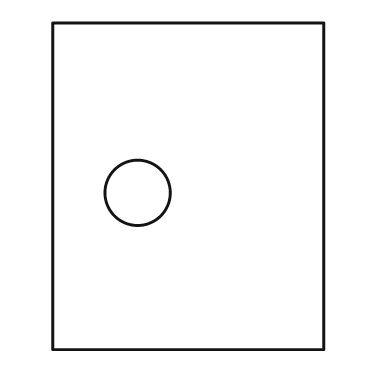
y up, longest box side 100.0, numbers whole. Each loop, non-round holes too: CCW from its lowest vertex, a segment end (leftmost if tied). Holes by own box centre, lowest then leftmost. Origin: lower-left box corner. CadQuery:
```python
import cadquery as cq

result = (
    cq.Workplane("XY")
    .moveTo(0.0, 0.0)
    .lineTo(83.0, 0.0)
    .lineTo(83.0, 100.0)
    .lineTo(0.0, 100.0)
    .close()
    .moveTo(26.0, 48.0)
    .circle(10.0)
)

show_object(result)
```